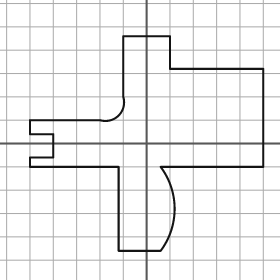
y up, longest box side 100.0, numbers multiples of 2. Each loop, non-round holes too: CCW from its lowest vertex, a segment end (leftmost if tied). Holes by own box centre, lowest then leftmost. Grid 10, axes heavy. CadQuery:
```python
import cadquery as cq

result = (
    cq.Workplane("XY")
    .moveTo(-12.0, -46.0)
    .lineTo(6.0, -46.0)
    .threePointArc((12.0, -28.0), (6.0, -10.0))
    .lineTo(50.0, -10.0)
    .lineTo(50.0, 32.0)
    .lineTo(10.0, 32.0)
    .lineTo(10.0, 46.0)
    .lineTo(-10.0, 46.0)
    .lineTo(-10.0, 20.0)
    .threePointArc((-12.0, 12.0), (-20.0, 10.0))
    .lineTo(-50.0, 10.0)
    .lineTo(-50.0, 4.0)
    .lineTo(-40.0, 4.0)
    .lineTo(-40.0, -6.0)
    .lineTo(-50.0, -6.0)
    .lineTo(-50.0, -10.0)
    .lineTo(-12.0, -10.0)
    .close()
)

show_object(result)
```